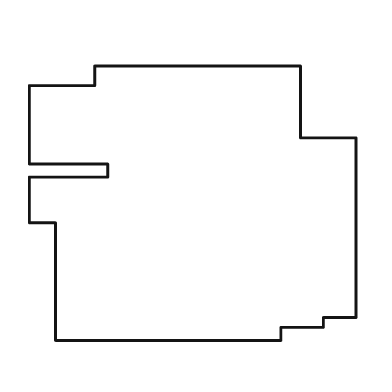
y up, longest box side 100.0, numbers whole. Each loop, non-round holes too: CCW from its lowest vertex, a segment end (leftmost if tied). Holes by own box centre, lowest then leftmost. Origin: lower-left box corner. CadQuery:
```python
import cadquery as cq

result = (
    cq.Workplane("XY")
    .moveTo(8.0, 0.0)
    .lineTo(77.0, 0.0)
    .lineTo(77.0, 4.0)
    .lineTo(90.0, 4.0)
    .lineTo(90.0, 7.0)
    .lineTo(100.0, 7.0)
    .lineTo(100.0, 62.0)
    .lineTo(83.0, 62.0)
    .lineTo(83.0, 84.0)
    .lineTo(20.0, 84.0)
    .lineTo(20.0, 78.0)
    .lineTo(0.0, 78.0)
    .lineTo(0.0, 54.0)
    .lineTo(24.0, 54.0)
    .lineTo(24.0, 50.0)
    .lineTo(0.0, 50.0)
    .lineTo(0.0, 36.0)
    .lineTo(8.0, 36.0)
    .close()
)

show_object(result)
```